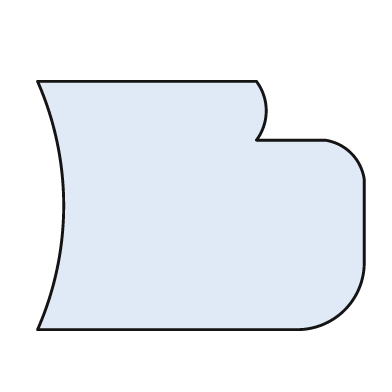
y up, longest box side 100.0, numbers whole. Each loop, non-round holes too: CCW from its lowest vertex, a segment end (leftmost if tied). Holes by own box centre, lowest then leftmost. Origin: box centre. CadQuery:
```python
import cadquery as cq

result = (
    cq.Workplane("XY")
    .moveTo(-50.0, -38.0)
    .lineTo(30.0, -38.0)
    .threePointArc((44.0, -32.0), (50.0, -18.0))
    .lineTo(50.0, 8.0)
    .threePointArc((46.0, 16.0), (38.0, 20.0))
    .lineTo(17.0, 20.0)
    .threePointArc((20.0, 29.0), (17.0, 38.0))
    .lineTo(-50.0, 38.0)
    .threePointArc((-42.0, 0.0), (-50.0, -38.0))
    .close()
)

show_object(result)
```